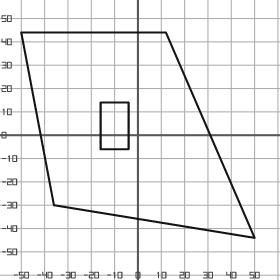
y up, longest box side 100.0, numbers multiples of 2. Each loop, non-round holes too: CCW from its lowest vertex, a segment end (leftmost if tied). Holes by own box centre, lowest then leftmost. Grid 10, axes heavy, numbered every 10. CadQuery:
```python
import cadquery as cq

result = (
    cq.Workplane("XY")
    .moveTo(50.0, -44.0)
    .lineTo(12.0, 44.0)
    .lineTo(-50.0, 44.0)
    .lineTo(-36.0, -30.0)
    .close()
    .moveTo(-16.0, -6.0)
    .lineTo(-4.0, -6.0)
    .lineTo(-4.0, 14.0)
    .lineTo(-16.0, 14.0)
    .close()
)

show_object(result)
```